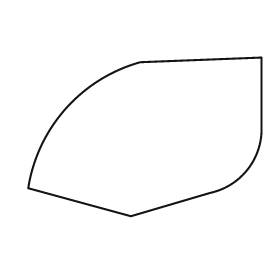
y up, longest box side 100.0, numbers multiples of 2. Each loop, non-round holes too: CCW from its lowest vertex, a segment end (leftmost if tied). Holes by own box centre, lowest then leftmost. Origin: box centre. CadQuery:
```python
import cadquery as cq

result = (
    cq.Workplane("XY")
    .moveTo(-6.0, -34.0)
    .lineTo(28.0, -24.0)
    .threePointArc((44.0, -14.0), (50.0, 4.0))
    .lineTo(50.0, 34.0)
    .lineTo(-2.0, 32.0)
    .threePointArc((-34.0, 12.0), (-50.0, -22.0))
    .close()
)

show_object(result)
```